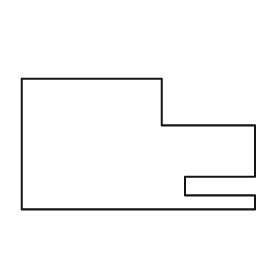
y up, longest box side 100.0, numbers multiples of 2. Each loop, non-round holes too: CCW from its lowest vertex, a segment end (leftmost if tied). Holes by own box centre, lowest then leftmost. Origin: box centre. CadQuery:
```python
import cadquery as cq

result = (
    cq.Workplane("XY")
    .moveTo(-50.0, -28.0)
    .lineTo(50.0, -28.0)
    .lineTo(50.0, -22.0)
    .lineTo(20.0, -22.0)
    .lineTo(20.0, -14.0)
    .lineTo(50.0, -14.0)
    .lineTo(50.0, 8.0)
    .lineTo(10.0, 8.0)
    .lineTo(10.0, 28.0)
    .lineTo(-50.0, 28.0)
    .close()
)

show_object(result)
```